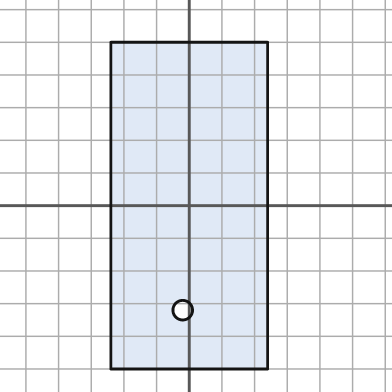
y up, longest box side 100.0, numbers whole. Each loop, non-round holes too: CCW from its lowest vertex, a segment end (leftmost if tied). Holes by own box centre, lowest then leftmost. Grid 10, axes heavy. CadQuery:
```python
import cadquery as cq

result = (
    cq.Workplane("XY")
    .moveTo(-24.0, -50.0)
    .lineTo(24.0, -50.0)
    .lineTo(24.0, 50.0)
    .lineTo(-24.0, 50.0)
    .close()
    .moveTo(-2.0, -32.0)
    .circle(3.0)
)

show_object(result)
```